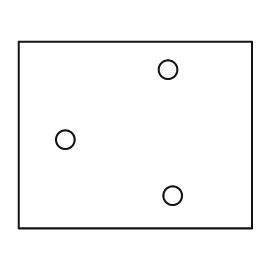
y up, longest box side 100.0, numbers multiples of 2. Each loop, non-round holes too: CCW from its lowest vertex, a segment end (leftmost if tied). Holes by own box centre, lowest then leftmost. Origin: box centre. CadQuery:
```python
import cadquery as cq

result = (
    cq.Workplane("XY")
    .moveTo(-50.0, -40.0)
    .lineTo(50.0, -40.0)
    .lineTo(50.0, 40.0)
    .lineTo(-50.0, 40.0)
    .close()
    .moveTo(16.0, -26.0)
    .circle(4.0)
    .moveTo(-30.0, -2.0)
    .circle(4.0)
    .moveTo(14.0, 28.0)
    .circle(4.0)
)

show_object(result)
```